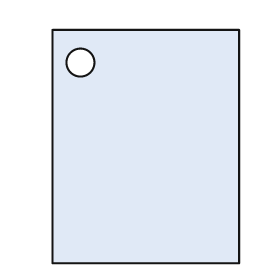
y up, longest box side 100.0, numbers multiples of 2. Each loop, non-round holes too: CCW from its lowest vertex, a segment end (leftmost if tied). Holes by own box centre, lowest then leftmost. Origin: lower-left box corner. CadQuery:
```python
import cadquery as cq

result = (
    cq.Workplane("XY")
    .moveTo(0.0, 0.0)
    .lineTo(80.0, 0.0)
    .lineTo(80.0, 100.0)
    .lineTo(0.0, 100.0)
    .close()
    .moveTo(12.0, 86.0)
    .circle(6.0)
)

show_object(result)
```